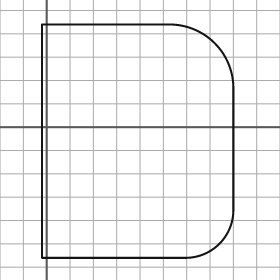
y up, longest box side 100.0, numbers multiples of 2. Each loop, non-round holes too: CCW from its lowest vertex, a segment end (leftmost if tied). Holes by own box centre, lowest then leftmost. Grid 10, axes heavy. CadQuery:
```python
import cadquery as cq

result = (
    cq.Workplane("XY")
    .moveTo(-2.0, -56.0)
    .lineTo(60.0, -56.0)
    .threePointArc((74.0, -50.0), (80.0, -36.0))
    .lineTo(80.0, 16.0)
    .threePointArc((72.0, 36.0), (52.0, 44.0))
    .lineTo(-2.0, 44.0)
    .close()
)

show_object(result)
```